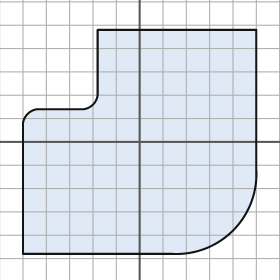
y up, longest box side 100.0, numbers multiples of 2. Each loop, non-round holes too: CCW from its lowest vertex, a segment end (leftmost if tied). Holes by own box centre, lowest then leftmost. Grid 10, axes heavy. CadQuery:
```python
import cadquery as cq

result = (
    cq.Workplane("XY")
    .moveTo(-50.0, -48.0)
    .lineTo(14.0, -48.0)
    .threePointArc((40.0, -38.0), (50.0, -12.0))
    .lineTo(50.0, 48.0)
    .lineTo(-18.0, 48.0)
    .lineTo(-18.0, 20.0)
    .threePointArc((-20.0, 16.0), (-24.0, 14.0))
    .lineTo(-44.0, 14.0)
    .threePointArc((-48.0, 12.0), (-50.0, 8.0))
    .close()
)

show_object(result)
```